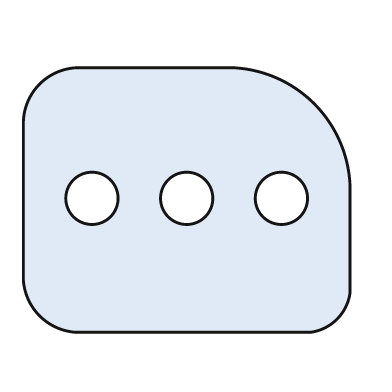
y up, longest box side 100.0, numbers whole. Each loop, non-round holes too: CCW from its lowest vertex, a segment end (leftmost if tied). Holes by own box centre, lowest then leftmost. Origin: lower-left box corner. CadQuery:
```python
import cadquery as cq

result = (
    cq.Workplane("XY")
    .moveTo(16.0, 0.0)
    .lineTo(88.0, 0.0)
    .threePointArc((96.0, 4.0), (100.0, 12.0))
    .lineTo(100.0, 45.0)
    .threePointArc((89.0, 70.0), (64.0, 81.0))
    .lineTo(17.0, 81.0)
    .threePointArc((5.0, 76.0), (0.0, 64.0))
    .lineTo(0.0, 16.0)
    .threePointArc((5.0, 5.0), (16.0, 0.0))
    .close()
    .moveTo(21.0, 41.0)
    .circle(8.0)
    .moveTo(50.0, 41.0)
    .circle(8.0)
    .moveTo(79.0, 41.0)
    .circle(8.0)
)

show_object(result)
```